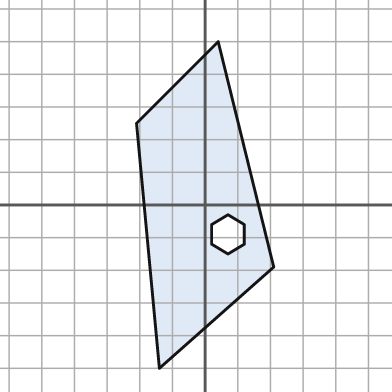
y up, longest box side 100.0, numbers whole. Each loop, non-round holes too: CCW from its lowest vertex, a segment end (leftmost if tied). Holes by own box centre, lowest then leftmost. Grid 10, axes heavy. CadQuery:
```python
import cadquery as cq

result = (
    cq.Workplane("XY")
    .moveTo(-14.0, -50.0)
    .lineTo(21.0, -19.0)
    .lineTo(4.0, 50.0)
    .lineTo(-21.0, 25.0)
    .close()
    .moveTo(7.0, -15.0)
    .lineTo(12.0, -12.0)
    .lineTo(12.0, -6.0)
    .lineTo(7.0, -3.0)
    .lineTo(2.0, -6.0)
    .lineTo(2.0, -12.0)
    .close()
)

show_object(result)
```